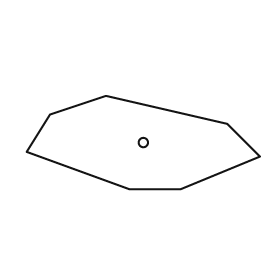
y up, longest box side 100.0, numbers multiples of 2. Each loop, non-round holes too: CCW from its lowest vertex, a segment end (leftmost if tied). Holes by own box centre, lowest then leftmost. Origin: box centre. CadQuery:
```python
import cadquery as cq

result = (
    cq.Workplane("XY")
    .moveTo(-6.0, -20.0)
    .lineTo(16.0, -20.0)
    .lineTo(50.0, -6.0)
    .lineTo(36.0, 8.0)
    .lineTo(-16.0, 20.0)
    .lineTo(-40.0, 12.0)
    .lineTo(-50.0, -4.0)
    .close()
    .moveTo(0.0, 0.0)
    .circle(2.0)
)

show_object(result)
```